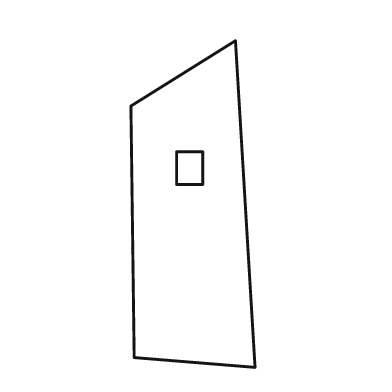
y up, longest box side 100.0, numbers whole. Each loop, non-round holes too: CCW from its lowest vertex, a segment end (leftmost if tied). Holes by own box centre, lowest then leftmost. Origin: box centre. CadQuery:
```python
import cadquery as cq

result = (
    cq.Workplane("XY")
    .moveTo(19.0, -50.0)
    .lineTo(13.0, 50.0)
    .lineTo(-19.0, 30.0)
    .lineTo(-18.0, -47.0)
    .close()
    .moveTo(-5.0, 6.0)
    .lineTo(3.0, 6.0)
    .lineTo(3.0, 16.0)
    .lineTo(-5.0, 16.0)
    .close()
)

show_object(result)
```